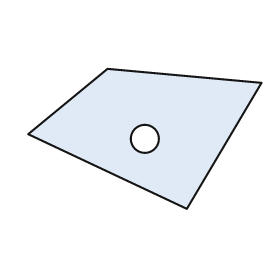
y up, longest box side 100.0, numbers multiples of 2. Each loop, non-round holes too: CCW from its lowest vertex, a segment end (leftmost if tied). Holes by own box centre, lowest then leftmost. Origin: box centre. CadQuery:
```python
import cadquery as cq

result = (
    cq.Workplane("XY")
    .moveTo(18.0, -30.0)
    .lineTo(50.0, 24.0)
    .lineTo(-16.0, 30.0)
    .lineTo(-50.0, 2.0)
    .close()
    .moveTo(0.0, 0.0)
    .circle(6.0)
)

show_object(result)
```